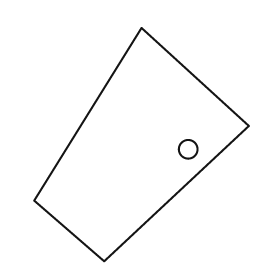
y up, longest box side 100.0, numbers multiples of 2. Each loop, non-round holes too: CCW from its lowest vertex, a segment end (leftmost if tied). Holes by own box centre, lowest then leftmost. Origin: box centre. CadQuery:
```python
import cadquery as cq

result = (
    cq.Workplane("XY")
    .moveTo(-16.0, -50.0)
    .lineTo(46.0, 8.0)
    .lineTo(0.0, 50.0)
    .lineTo(-46.0, -24.0)
    .close()
    .moveTo(20.0, -2.0)
    .circle(4.0)
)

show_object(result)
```